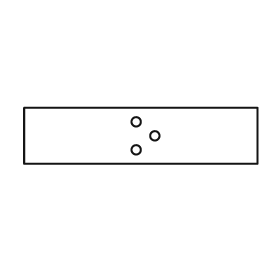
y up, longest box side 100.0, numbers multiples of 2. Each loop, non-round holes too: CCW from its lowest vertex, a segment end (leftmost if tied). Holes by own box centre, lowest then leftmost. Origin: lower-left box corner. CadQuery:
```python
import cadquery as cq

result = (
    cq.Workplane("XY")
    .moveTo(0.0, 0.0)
    .lineTo(100.0, 0.0)
    .lineTo(100.0, 24.0)
    .lineTo(0.0, 24.0)
    .close()
    .moveTo(48.0, 6.0)
    .circle(2.0)
    .moveTo(56.0, 12.0)
    .circle(2.0)
    .moveTo(48.0, 18.0)
    .circle(2.0)
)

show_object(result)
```